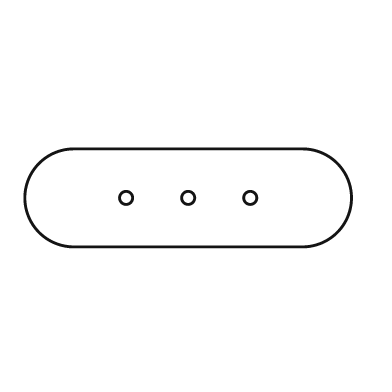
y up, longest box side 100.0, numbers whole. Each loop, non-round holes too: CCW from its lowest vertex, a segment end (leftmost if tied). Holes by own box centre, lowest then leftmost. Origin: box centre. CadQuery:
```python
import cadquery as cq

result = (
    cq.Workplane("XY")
    .moveTo(-35.0, -15.0)
    .lineTo(35.0, -15.0)
    .threePointArc((50.0, 0.0), (35.0, 15.0))
    .lineTo(-35.0, 15.0)
    .threePointArc((-50.0, 0.0), (-35.0, -15.0))
    .close()
    .moveTo(-19.0, 0.0)
    .circle(2.0)
    .moveTo(0.0, 0.0)
    .circle(2.0)
    .moveTo(19.0, 0.0)
    .circle(2.0)
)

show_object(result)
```